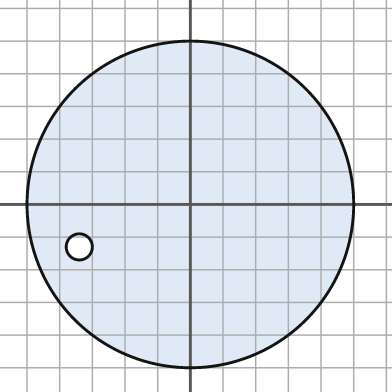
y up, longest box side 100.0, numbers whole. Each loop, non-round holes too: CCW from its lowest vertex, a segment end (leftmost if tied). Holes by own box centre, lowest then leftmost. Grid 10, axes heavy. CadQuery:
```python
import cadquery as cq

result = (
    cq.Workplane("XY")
    .moveTo(0.0, 0.0)
    .circle(50.0)
    .moveTo(-34.0, -13.0)
    .circle(4.0)
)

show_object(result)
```